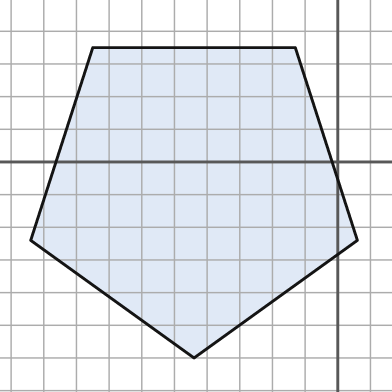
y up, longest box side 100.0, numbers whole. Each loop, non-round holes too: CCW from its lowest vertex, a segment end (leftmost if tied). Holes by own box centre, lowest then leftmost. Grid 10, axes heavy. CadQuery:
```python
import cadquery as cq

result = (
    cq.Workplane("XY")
    .moveTo(-44.0, -60.0)
    .lineTo(6.0, -24.0)
    .lineTo(-13.0, 35.0)
    .lineTo(-75.0, 35.0)
    .lineTo(-94.0, -24.0)
    .close()
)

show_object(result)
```